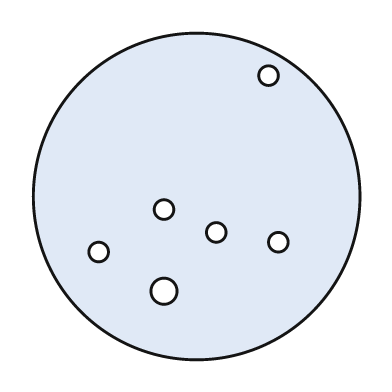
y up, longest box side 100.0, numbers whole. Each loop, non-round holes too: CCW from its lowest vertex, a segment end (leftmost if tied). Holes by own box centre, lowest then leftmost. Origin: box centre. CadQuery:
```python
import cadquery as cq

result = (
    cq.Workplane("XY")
    .moveTo(0.0, 0.0)
    .circle(50.0)
    .moveTo(-10.0, -29.0)
    .circle(4.0)
    .moveTo(-30.0, -17.0)
    .circle(3.0)
    .moveTo(25.0, -14.0)
    .circle(3.0)
    .moveTo(6.0, -11.0)
    .circle(3.0)
    .moveTo(-10.0, -4.0)
    .circle(3.0)
    .moveTo(22.0, 37.0)
    .circle(3.0)
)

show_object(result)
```